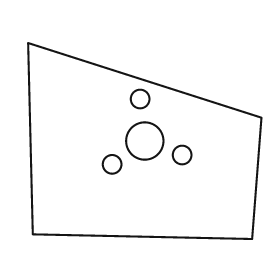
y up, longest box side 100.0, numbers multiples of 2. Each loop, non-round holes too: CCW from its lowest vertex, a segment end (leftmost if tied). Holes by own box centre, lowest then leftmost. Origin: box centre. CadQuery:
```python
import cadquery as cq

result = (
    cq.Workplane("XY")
    .moveTo(46.0, -42.0)
    .lineTo(50.0, 10.0)
    .lineTo(-50.0, 42.0)
    .lineTo(-48.0, -40.0)
    .close()
    .moveTo(-14.0, -10.0)
    .circle(4.0)
    .moveTo(16.0, -6.0)
    .circle(4.0)
    .moveTo(0.0, 0.0)
    .circle(8.0)
    .moveTo(-2.0, 18.0)
    .circle(4.0)
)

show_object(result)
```